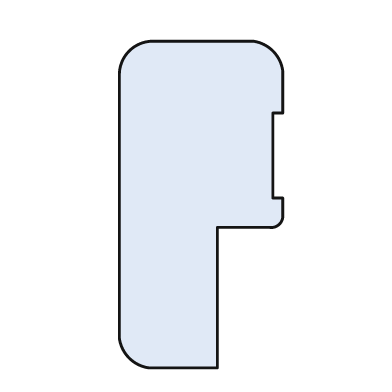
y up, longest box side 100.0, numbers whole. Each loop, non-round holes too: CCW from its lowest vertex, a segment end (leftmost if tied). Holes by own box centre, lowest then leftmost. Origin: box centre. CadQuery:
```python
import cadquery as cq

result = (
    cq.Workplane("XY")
    .moveTo(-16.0, -50.0)
    .lineTo(5.0, -50.0)
    .lineTo(5.0, -7.0)
    .lineTo(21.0, -7.0)
    .threePointArc((24.0, -6.0), (25.0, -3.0))
    .lineTo(25.0, 2.0)
    .lineTo(22.0, 2.0)
    .lineTo(22.0, 28.0)
    .lineTo(25.0, 28.0)
    .lineTo(25.0, 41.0)
    .threePointArc((22.0, 47.0), (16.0, 50.0))
    .lineTo(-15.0, 50.0)
    .threePointArc((-22.0, 47.0), (-25.0, 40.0))
    .lineTo(-25.0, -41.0)
    .threePointArc((-22.0, -47.0), (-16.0, -50.0))
    .close()
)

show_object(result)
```